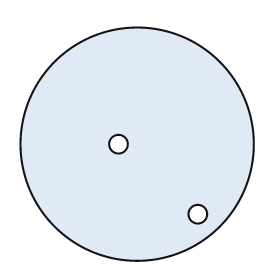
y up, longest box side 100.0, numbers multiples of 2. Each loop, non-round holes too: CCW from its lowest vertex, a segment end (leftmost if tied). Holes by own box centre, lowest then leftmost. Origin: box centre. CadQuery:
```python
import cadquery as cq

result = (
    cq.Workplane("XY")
    .moveTo(0.0, 0.0)
    .circle(50.0)
    .moveTo(26.0, -30.0)
    .circle(4.0)
    .moveTo(-8.0, 0.0)
    .circle(4.0)
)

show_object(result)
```